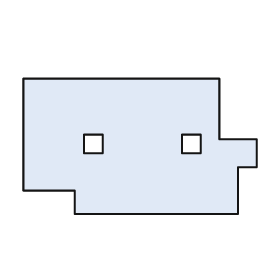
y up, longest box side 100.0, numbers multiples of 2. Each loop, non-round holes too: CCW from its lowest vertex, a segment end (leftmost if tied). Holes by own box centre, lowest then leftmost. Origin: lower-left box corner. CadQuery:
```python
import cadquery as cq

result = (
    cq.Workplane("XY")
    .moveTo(22.0, 0.0)
    .lineTo(92.0, 0.0)
    .lineTo(92.0, 20.0)
    .lineTo(100.0, 20.0)
    .lineTo(100.0, 32.0)
    .lineTo(84.0, 32.0)
    .lineTo(84.0, 58.0)
    .lineTo(0.0, 58.0)
    .lineTo(0.0, 10.0)
    .lineTo(22.0, 10.0)
    .close()
    .moveTo(26.0, 26.0)
    .lineTo(34.0, 26.0)
    .lineTo(34.0, 34.0)
    .lineTo(26.0, 34.0)
    .close()
    .moveTo(68.0, 26.0)
    .lineTo(76.0, 26.0)
    .lineTo(76.0, 34.0)
    .lineTo(68.0, 34.0)
    .close()
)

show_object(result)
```